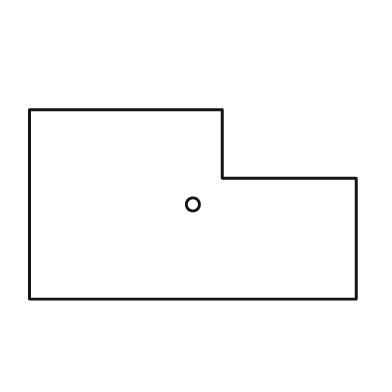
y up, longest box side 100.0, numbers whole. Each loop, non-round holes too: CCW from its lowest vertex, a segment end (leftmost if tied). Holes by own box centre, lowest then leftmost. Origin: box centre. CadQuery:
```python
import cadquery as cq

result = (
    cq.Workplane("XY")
    .moveTo(-50.0, -29.0)
    .lineTo(50.0, -29.0)
    .lineTo(50.0, 8.0)
    .lineTo(9.0, 8.0)
    .lineTo(9.0, 29.0)
    .lineTo(-50.0, 29.0)
    .close()
    .moveTo(0.0, 0.0)
    .circle(2.0)
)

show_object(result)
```